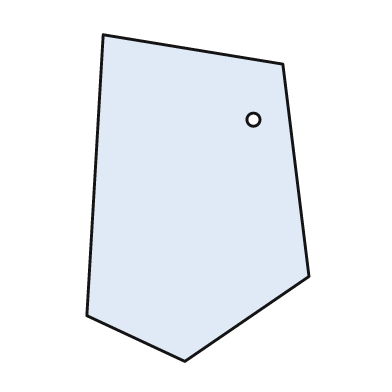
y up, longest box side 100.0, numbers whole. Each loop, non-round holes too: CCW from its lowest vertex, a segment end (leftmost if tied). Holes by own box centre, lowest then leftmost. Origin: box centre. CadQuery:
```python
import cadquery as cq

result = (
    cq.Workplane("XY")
    .moveTo(-4.0, -50.0)
    .lineTo(34.0, -24.0)
    .lineTo(26.0, 41.0)
    .lineTo(-29.0, 50.0)
    .lineTo(-34.0, -36.0)
    .close()
    .moveTo(17.0, 24.0)
    .circle(2.0)
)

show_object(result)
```